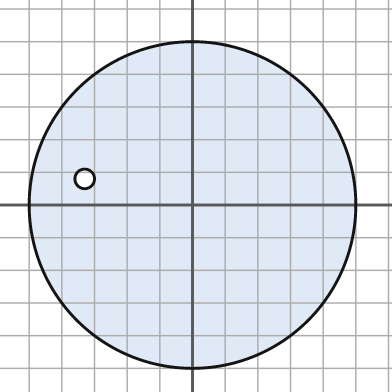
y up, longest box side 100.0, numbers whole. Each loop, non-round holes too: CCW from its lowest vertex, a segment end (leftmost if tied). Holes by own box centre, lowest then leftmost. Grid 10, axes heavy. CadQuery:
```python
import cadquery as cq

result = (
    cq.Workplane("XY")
    .moveTo(0.0, 0.0)
    .circle(50.0)
    .moveTo(-33.0, 8.0)
    .circle(3.0)
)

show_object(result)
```